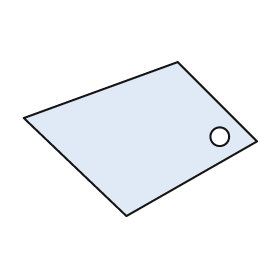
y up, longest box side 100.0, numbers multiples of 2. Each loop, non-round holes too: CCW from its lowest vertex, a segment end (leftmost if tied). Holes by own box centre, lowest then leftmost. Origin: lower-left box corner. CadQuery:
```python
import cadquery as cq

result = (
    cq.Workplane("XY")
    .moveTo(44.0, 0.0)
    .lineTo(100.0, 32.0)
    .lineTo(66.0, 66.0)
    .lineTo(0.0, 42.0)
    .close()
    .moveTo(84.0, 34.0)
    .circle(4.0)
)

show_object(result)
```